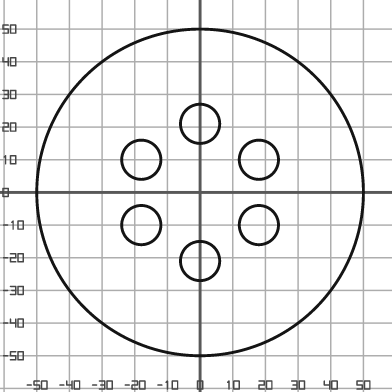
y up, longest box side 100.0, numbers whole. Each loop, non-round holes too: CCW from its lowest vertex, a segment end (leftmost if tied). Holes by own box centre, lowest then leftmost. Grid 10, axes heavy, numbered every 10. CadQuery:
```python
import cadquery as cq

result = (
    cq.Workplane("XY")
    .moveTo(0.0, 0.0)
    .circle(50.0)
    .moveTo(0.0, -21.0)
    .circle(6.0)
    .moveTo(-18.0, -10.0)
    .circle(6.0)
    .moveTo(18.0, -10.0)
    .circle(6.0)
    .moveTo(-18.0, 10.0)
    .circle(6.0)
    .moveTo(18.0, 10.0)
    .circle(6.0)
    .moveTo(0.0, 21.0)
    .circle(6.0)
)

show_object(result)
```